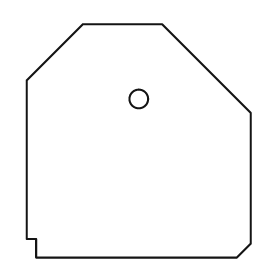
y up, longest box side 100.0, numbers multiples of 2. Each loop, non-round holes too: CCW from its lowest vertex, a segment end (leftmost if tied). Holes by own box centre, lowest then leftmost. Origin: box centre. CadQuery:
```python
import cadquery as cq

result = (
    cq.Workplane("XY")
    .moveTo(-44.0, -50.0)
    .lineTo(42.0, -50.0)
    .lineTo(48.0, -44.0)
    .lineTo(48.0, 12.0)
    .lineTo(10.0, 50.0)
    .lineTo(-24.0, 50.0)
    .lineTo(-48.0, 26.0)
    .lineTo(-48.0, -42.0)
    .lineTo(-44.0, -42.0)
    .close()
    .moveTo(0.0, 18.0)
    .circle(4.0)
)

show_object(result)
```